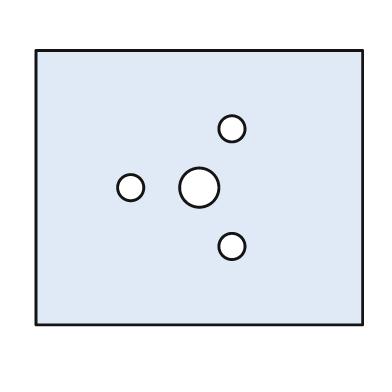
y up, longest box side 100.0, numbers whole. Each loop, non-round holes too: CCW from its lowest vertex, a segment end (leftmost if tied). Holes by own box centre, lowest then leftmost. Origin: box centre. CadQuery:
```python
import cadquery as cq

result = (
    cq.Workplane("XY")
    .moveTo(-50.0, -42.0)
    .lineTo(50.0, -42.0)
    .lineTo(50.0, 42.0)
    .lineTo(-50.0, 42.0)
    .close()
    .moveTo(10.0, -18.0)
    .circle(4.0)
    .moveTo(-21.0, 0.0)
    .circle(4.0)
    .moveTo(0.0, 0.0)
    .circle(6.0)
    .moveTo(10.0, 18.0)
    .circle(4.0)
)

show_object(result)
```